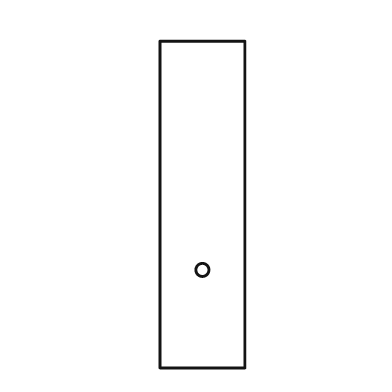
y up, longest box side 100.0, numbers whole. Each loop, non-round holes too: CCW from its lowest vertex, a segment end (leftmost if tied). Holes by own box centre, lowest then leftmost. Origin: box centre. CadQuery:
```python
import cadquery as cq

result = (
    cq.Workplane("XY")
    .moveTo(-13.0, -50.0)
    .lineTo(13.0, -50.0)
    .lineTo(13.0, 50.0)
    .lineTo(-13.0, 50.0)
    .close()
    .moveTo(0.0, -20.0)
    .circle(2.0)
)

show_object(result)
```